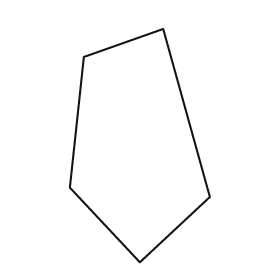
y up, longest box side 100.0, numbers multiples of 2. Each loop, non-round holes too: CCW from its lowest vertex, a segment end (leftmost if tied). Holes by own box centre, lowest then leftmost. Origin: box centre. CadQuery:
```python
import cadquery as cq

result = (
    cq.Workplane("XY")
    .moveTo(0.0, -50.0)
    .lineTo(30.0, -22.0)
    .lineTo(10.0, 50.0)
    .lineTo(-24.0, 38.0)
    .lineTo(-30.0, -18.0)
    .close()
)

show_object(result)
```